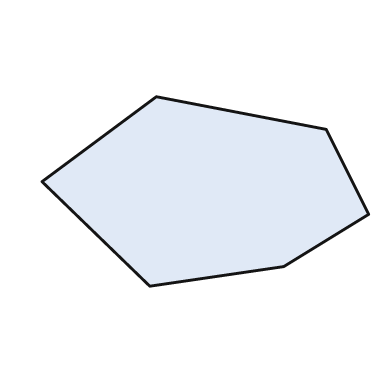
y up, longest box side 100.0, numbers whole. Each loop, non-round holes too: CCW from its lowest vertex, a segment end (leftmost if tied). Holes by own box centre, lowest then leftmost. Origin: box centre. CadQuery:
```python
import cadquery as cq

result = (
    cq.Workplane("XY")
    .moveTo(-17.0, -29.0)
    .lineTo(24.0, -23.0)
    .lineTo(50.0, -7.0)
    .lineTo(37.0, 19.0)
    .lineTo(-15.0, 29.0)
    .lineTo(-50.0, 3.0)
    .close()
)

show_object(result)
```